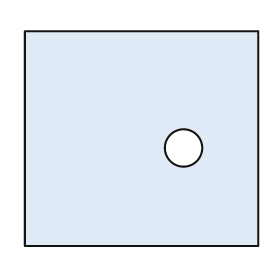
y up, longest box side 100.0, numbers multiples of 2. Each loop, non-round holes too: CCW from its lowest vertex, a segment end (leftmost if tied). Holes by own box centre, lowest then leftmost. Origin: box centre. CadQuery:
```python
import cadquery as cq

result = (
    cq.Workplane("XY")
    .moveTo(-50.0, -46.0)
    .lineTo(50.0, -46.0)
    .lineTo(50.0, 46.0)
    .lineTo(-50.0, 46.0)
    .close()
    .moveTo(18.0, -4.0)
    .circle(8.0)
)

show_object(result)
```